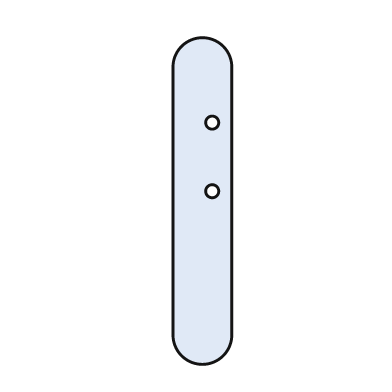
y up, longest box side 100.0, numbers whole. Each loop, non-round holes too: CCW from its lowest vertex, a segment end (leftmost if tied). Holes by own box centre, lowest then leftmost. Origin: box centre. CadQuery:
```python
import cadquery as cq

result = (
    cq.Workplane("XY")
    .moveTo(-9.0, -41.0)
    .threePointArc((0.0, -50.0), (9.0, -41.0))
    .lineTo(9.0, 41.0)
    .threePointArc((0.0, 50.0), (-9.0, 41.0))
    .close()
    .moveTo(3.0, 3.0)
    .circle(2.0)
    .moveTo(3.0, 24.0)
    .circle(2.0)
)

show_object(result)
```